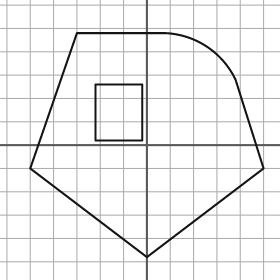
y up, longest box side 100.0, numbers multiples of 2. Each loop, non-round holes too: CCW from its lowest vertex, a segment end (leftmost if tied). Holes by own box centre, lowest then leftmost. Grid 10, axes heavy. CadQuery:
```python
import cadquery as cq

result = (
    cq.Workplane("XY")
    .moveTo(0.0, -48.0)
    .lineTo(50.0, -10.0)
    .lineTo(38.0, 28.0)
    .threePointArc((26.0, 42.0), (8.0, 48.0))
    .lineTo(-30.0, 48.0)
    .lineTo(-50.0, -10.0)
    .close()
    .moveTo(-22.0, 2.0)
    .lineTo(-2.0, 2.0)
    .lineTo(-2.0, 26.0)
    .lineTo(-22.0, 26.0)
    .close()
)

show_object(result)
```